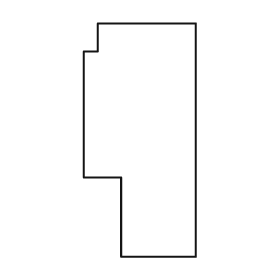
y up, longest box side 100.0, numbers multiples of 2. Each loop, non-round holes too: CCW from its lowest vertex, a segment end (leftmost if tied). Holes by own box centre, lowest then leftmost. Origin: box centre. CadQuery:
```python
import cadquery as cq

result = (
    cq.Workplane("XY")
    .moveTo(-8.0, -50.0)
    .lineTo(24.0, -50.0)
    .lineTo(24.0, 50.0)
    .lineTo(-18.0, 50.0)
    .lineTo(-18.0, 38.0)
    .lineTo(-24.0, 38.0)
    .lineTo(-24.0, -16.0)
    .lineTo(-8.0, -16.0)
    .close()
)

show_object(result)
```